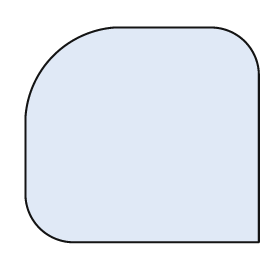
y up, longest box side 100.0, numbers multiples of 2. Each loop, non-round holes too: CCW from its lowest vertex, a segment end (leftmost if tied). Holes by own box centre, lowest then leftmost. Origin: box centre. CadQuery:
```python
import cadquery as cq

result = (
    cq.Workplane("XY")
    .moveTo(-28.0, -46.0)
    .lineTo(50.0, -46.0)
    .lineTo(50.0, 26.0)
    .threePointArc((44.0, 40.0), (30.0, 46.0))
    .lineTo(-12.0, 46.0)
    .threePointArc((-38.0, 34.0), (-50.0, 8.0))
    .lineTo(-50.0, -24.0)
    .threePointArc((-44.0, -40.0), (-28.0, -46.0))
    .close()
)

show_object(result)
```